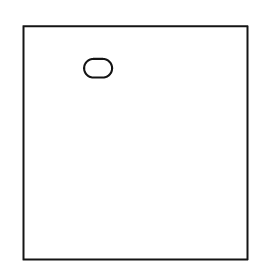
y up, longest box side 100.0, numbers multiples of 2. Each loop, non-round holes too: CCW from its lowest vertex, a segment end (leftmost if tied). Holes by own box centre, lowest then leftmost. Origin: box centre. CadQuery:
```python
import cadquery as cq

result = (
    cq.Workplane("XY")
    .moveTo(-48.0, -50.0)
    .lineTo(48.0, -50.0)
    .lineTo(48.0, 50.0)
    .lineTo(-48.0, 50.0)
    .close()
    .moveTo(-18.0, 28.0)
    .lineTo(-14.0, 28.0)
    .threePointArc((-10.0, 32.0), (-14.0, 36.0))
    .lineTo(-18.0, 36.0)
    .threePointArc((-22.0, 32.0), (-18.0, 28.0))
    .close()
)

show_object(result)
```